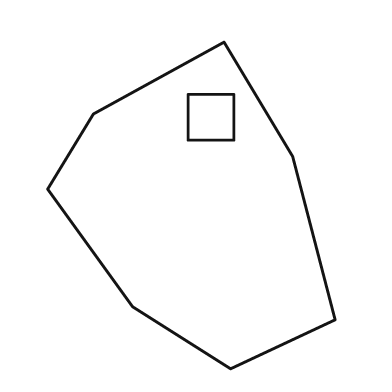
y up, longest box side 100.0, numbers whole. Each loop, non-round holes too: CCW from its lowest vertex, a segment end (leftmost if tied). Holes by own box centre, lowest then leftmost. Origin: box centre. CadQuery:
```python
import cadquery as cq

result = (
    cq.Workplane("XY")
    .moveTo(12.0, -50.0)
    .lineTo(44.0, -35.0)
    .lineTo(31.0, 15.0)
    .lineTo(10.0, 50.0)
    .lineTo(-30.0, 28.0)
    .lineTo(-44.0, 5.0)
    .lineTo(-18.0, -31.0)
    .close()
    .moveTo(-1.0, 20.0)
    .lineTo(13.0, 20.0)
    .lineTo(13.0, 34.0)
    .lineTo(-1.0, 34.0)
    .close()
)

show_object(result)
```